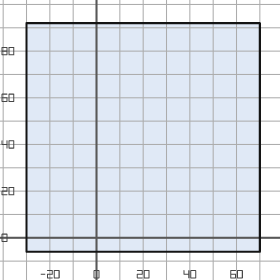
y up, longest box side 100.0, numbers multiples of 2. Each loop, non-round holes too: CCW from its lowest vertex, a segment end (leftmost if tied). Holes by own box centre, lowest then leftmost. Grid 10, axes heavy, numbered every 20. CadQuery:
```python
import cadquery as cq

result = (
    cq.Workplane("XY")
    .moveTo(-30.0, -6.0)
    .lineTo(70.0, -6.0)
    .lineTo(70.0, 92.0)
    .lineTo(-30.0, 92.0)
    .close()
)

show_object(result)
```